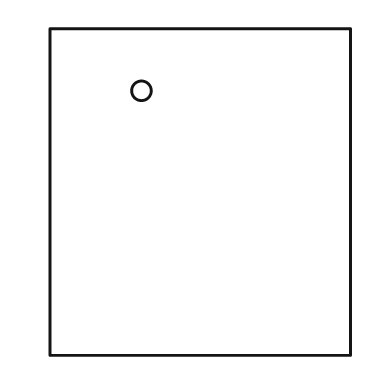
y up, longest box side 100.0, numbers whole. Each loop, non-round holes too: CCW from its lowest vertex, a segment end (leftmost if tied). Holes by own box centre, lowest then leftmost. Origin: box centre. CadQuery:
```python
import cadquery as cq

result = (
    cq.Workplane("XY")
    .moveTo(-46.0, -50.0)
    .lineTo(46.0, -50.0)
    .lineTo(46.0, 50.0)
    .lineTo(-46.0, 50.0)
    .close()
    .moveTo(-18.0, 31.0)
    .circle(3.0)
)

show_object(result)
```